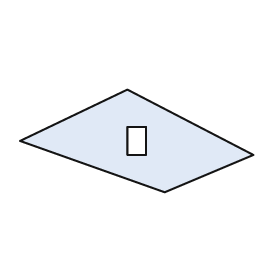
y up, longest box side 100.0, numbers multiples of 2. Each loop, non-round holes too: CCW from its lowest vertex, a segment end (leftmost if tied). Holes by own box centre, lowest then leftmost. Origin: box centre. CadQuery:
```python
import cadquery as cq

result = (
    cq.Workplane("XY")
    .moveTo(12.0, -22.0)
    .lineTo(50.0, -6.0)
    .lineTo(-4.0, 22.0)
    .lineTo(-50.0, 0.0)
    .close()
    .moveTo(-4.0, -6.0)
    .lineTo(4.0, -6.0)
    .lineTo(4.0, 6.0)
    .lineTo(-4.0, 6.0)
    .close()
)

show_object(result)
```